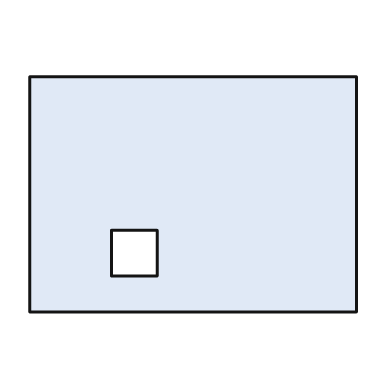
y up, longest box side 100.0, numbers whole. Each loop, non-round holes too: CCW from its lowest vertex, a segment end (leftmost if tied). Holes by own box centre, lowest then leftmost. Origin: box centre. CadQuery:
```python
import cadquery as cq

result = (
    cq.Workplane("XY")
    .moveTo(-50.0, -36.0)
    .lineTo(50.0, -36.0)
    .lineTo(50.0, 36.0)
    .lineTo(-50.0, 36.0)
    .close()
    .moveTo(-25.0, -25.0)
    .lineTo(-11.0, -25.0)
    .lineTo(-11.0, -11.0)
    .lineTo(-25.0, -11.0)
    .close()
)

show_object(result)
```